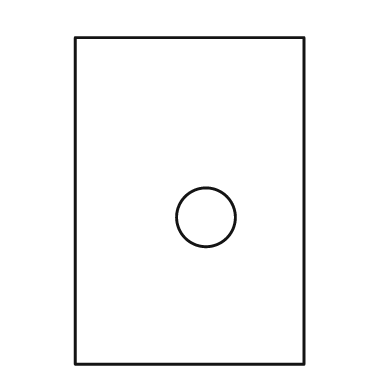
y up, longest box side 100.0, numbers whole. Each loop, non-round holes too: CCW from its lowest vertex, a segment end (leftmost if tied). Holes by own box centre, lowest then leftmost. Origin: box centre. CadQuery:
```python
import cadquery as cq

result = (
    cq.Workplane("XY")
    .moveTo(-35.0, -50.0)
    .lineTo(35.0, -50.0)
    .lineTo(35.0, 50.0)
    .lineTo(-35.0, 50.0)
    .close()
    .moveTo(5.0, -5.0)
    .circle(9.0)
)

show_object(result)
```